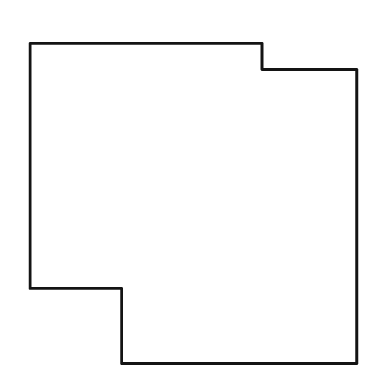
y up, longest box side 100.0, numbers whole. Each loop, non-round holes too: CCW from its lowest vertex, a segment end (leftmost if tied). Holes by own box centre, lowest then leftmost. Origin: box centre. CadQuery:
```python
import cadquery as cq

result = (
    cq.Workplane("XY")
    .moveTo(-22.0, -49.0)
    .lineTo(50.0, -49.0)
    .lineTo(50.0, 41.0)
    .lineTo(21.0, 41.0)
    .lineTo(21.0, 49.0)
    .lineTo(-50.0, 49.0)
    .lineTo(-50.0, -26.0)
    .lineTo(-22.0, -26.0)
    .close()
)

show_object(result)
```